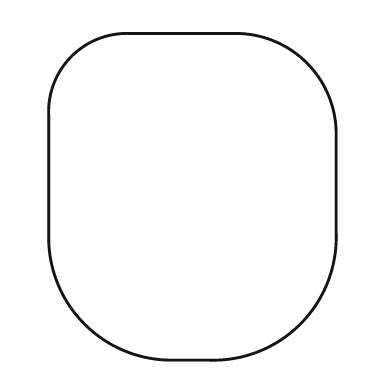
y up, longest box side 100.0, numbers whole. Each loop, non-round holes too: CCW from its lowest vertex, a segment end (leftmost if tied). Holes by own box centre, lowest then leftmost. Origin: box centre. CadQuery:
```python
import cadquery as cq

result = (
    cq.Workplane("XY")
    .moveTo(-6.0, -50.0)
    .lineTo(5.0, -50.0)
    .threePointArc((33.0, -39.0), (44.0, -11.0))
    .lineTo(44.0, 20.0)
    .threePointArc((35.0, 41.0), (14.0, 50.0))
    .lineTo(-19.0, 50.0)
    .threePointArc((-37.0, 43.0), (-44.0, 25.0))
    .lineTo(-44.0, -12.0)
    .threePointArc((-33.0, -39.0), (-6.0, -50.0))
    .close()
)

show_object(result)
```